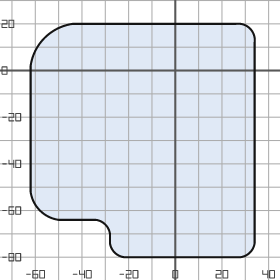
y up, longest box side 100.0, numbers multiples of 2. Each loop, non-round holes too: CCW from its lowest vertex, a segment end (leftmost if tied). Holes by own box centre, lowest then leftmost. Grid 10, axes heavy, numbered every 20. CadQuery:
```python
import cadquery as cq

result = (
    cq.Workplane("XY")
    .moveTo(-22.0, -80.0)
    .lineTo(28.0, -80.0)
    .threePointArc((32.0, -78.0), (34.0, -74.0))
    .lineTo(34.0, 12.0)
    .threePointArc((32.0, 18.0), (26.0, 20.0))
    .lineTo(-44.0, 20.0)
    .threePointArc((-56.0, 14.0), (-62.0, 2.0))
    .lineTo(-62.0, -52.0)
    .threePointArc((-58.0, -60.0), (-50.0, -64.0))
    .lineTo(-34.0, -64.0)
    .threePointArc((-30.0, -66.0), (-28.0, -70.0))
    .lineTo(-28.0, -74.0)
    .threePointArc((-26.0, -78.0), (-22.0, -80.0))
    .close()
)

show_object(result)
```